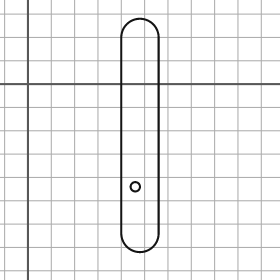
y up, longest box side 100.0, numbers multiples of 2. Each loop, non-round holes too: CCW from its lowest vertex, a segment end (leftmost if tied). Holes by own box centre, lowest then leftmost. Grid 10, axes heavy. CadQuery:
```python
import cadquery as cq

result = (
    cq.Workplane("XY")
    .moveTo(40.0, -64.0)
    .threePointArc((48.0, -72.0), (56.0, -64.0))
    .lineTo(56.0, 20.0)
    .threePointArc((48.0, 28.0), (40.0, 20.0))
    .close()
    .moveTo(46.0, -44.0)
    .circle(2.0)
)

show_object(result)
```